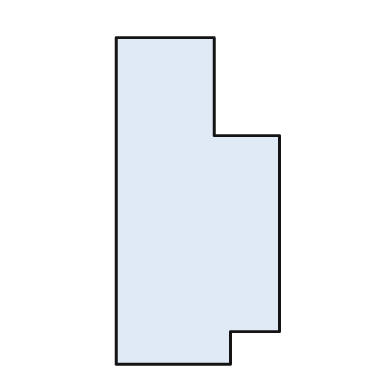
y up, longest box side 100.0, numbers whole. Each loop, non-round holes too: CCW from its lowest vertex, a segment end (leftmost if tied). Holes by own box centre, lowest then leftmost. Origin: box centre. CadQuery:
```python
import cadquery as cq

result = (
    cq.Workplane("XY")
    .moveTo(-25.0, -50.0)
    .lineTo(10.0, -50.0)
    .lineTo(10.0, -40.0)
    .lineTo(25.0, -40.0)
    .lineTo(25.0, 20.0)
    .lineTo(5.0, 20.0)
    .lineTo(5.0, 50.0)
    .lineTo(-25.0, 50.0)
    .close()
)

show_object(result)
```